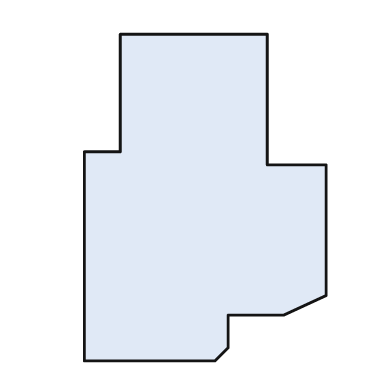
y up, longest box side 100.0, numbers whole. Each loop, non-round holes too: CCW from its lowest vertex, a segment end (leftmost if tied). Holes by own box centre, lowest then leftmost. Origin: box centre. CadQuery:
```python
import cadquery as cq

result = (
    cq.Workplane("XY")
    .moveTo(-37.0, -50.0)
    .lineTo(3.0, -50.0)
    .lineTo(7.0, -46.0)
    .lineTo(7.0, -36.0)
    .lineTo(24.0, -36.0)
    .lineTo(37.0, -30.0)
    .lineTo(37.0, 10.0)
    .lineTo(19.0, 10.0)
    .lineTo(19.0, 50.0)
    .lineTo(-26.0, 50.0)
    .lineTo(-26.0, 14.0)
    .lineTo(-37.0, 14.0)
    .close()
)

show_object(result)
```